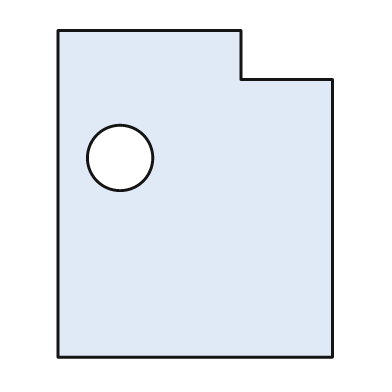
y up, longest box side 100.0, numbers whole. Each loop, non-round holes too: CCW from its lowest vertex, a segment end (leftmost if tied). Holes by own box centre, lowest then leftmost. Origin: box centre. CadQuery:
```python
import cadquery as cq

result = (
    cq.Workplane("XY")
    .moveTo(-42.0, -50.0)
    .lineTo(42.0, -50.0)
    .lineTo(42.0, 35.0)
    .lineTo(14.0, 35.0)
    .lineTo(14.0, 50.0)
    .lineTo(-42.0, 50.0)
    .close()
    .moveTo(-23.0, 11.0)
    .circle(10.0)
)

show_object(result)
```